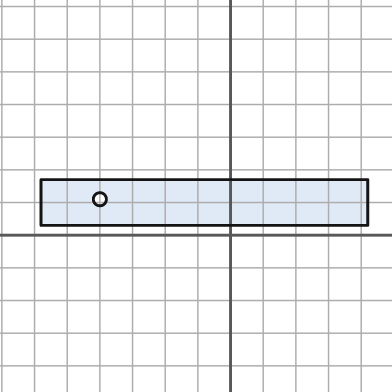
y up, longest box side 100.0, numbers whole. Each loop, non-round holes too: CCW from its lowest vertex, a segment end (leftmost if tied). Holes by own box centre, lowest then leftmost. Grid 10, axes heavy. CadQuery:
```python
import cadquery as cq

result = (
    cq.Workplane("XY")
    .moveTo(-58.0, 3.0)
    .lineTo(42.0, 3.0)
    .lineTo(42.0, 17.0)
    .lineTo(-58.0, 17.0)
    .close()
    .moveTo(-40.0, 11.0)
    .circle(2.0)
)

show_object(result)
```